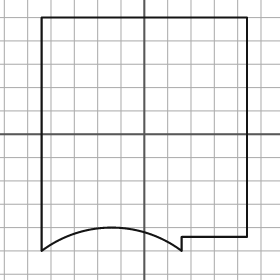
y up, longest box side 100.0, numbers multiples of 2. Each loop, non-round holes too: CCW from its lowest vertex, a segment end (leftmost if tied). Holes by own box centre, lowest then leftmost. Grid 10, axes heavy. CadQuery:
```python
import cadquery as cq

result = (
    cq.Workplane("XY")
    .moveTo(-44.0, -50.0)
    .threePointArc((-14.0, -40.0), (16.0, -50.0))
    .lineTo(16.0, -44.0)
    .lineTo(44.0, -44.0)
    .lineTo(44.0, 50.0)
    .lineTo(-44.0, 50.0)
    .close()
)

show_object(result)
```